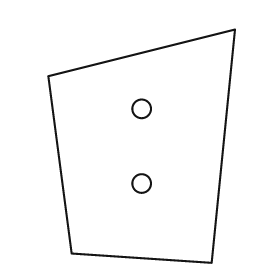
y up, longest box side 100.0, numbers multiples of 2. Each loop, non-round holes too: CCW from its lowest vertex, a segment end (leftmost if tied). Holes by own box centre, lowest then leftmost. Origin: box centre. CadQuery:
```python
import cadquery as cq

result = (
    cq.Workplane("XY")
    .moveTo(30.0, -50.0)
    .lineTo(40.0, 50.0)
    .lineTo(-40.0, 30.0)
    .lineTo(-30.0, -46.0)
    .close()
    .moveTo(0.0, -16.0)
    .circle(4.0)
    .moveTo(0.0, 16.0)
    .circle(4.0)
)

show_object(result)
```